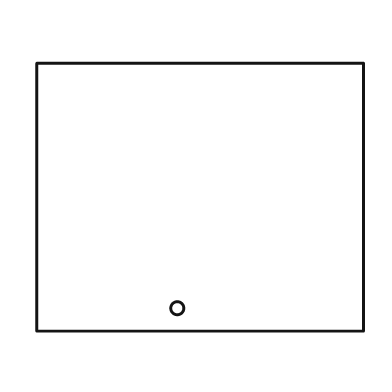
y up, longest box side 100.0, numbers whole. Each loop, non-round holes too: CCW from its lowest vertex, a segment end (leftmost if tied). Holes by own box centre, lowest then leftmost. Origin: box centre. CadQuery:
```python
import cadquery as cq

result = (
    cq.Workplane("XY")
    .moveTo(-50.0, -41.0)
    .lineTo(50.0, -41.0)
    .lineTo(50.0, 41.0)
    .lineTo(-50.0, 41.0)
    .close()
    .moveTo(-7.0, -34.0)
    .circle(2.0)
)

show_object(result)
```